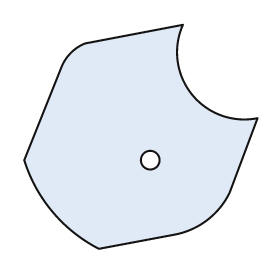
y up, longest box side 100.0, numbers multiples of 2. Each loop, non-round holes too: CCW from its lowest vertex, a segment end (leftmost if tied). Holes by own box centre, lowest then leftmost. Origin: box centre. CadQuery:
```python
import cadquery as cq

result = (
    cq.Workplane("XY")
    .moveTo(-18.0, -48.0)
    .lineTo(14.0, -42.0)
    .threePointArc((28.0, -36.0), (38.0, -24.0))
    .lineTo(50.0, 8.0)
    .threePointArc((22.0, 18.0), (18.0, 48.0))
    .lineTo(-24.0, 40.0)
    .threePointArc((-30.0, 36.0), (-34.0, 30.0))
    .lineTo(-50.0, -10.0)
    .threePointArc((-38.0, -32.0), (-18.0, -48.0))
    .close()
    .moveTo(4.0, -10.0)
    .circle(4.0)
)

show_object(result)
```